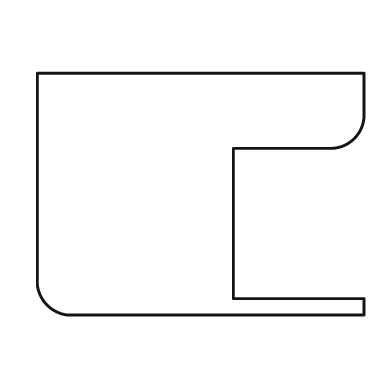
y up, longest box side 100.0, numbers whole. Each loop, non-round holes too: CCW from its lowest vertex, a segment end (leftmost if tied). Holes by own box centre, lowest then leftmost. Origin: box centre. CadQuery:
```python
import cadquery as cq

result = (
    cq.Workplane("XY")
    .moveTo(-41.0, -37.0)
    .lineTo(50.0, -37.0)
    .lineTo(50.0, -32.0)
    .lineTo(10.0, -32.0)
    .lineTo(10.0, 14.0)
    .lineTo(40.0, 14.0)
    .threePointArc((47.0, 17.0), (50.0, 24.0))
    .lineTo(50.0, 37.0)
    .lineTo(-50.0, 37.0)
    .lineTo(-50.0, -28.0)
    .threePointArc((-47.0, -34.0), (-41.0, -37.0))
    .close()
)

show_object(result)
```